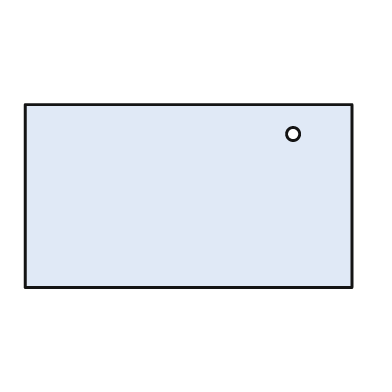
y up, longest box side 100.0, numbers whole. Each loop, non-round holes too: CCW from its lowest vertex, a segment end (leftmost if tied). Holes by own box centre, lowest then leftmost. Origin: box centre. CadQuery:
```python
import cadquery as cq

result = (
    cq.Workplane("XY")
    .moveTo(-50.0, -28.0)
    .lineTo(50.0, -28.0)
    .lineTo(50.0, 28.0)
    .lineTo(-50.0, 28.0)
    .close()
    .moveTo(32.0, 19.0)
    .circle(2.0)
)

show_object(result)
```